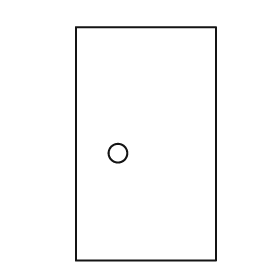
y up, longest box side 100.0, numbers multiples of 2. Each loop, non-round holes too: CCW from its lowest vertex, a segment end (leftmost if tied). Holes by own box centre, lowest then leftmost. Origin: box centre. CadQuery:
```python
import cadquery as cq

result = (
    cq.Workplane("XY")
    .moveTo(-30.0, -50.0)
    .lineTo(30.0, -50.0)
    .lineTo(30.0, 50.0)
    .lineTo(-30.0, 50.0)
    .close()
    .moveTo(-12.0, -4.0)
    .circle(4.0)
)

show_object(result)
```